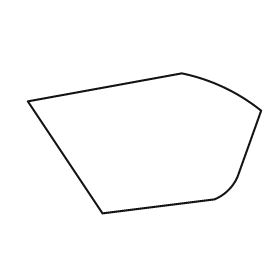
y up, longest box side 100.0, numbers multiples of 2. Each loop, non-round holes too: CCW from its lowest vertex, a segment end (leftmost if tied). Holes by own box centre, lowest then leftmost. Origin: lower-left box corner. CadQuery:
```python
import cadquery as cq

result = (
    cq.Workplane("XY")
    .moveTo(32.0, 0.0)
    .lineTo(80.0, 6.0)
    .threePointArc((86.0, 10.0), (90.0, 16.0))
    .lineTo(100.0, 44.0)
    .threePointArc((84.0, 54.0), (66.0, 60.0))
    .lineTo(0.0, 48.0)
    .close()
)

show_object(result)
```